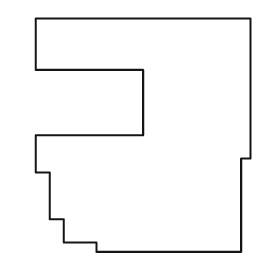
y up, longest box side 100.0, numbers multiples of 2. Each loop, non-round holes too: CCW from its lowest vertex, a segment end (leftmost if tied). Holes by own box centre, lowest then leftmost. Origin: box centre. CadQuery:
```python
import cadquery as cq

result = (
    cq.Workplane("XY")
    .moveTo(-20.0, -50.0)
    .lineTo(42.0, -50.0)
    .lineTo(42.0, -10.0)
    .lineTo(46.0, -10.0)
    .lineTo(46.0, 50.0)
    .lineTo(-46.0, 50.0)
    .lineTo(-46.0, 28.0)
    .lineTo(0.0, 28.0)
    .lineTo(0.0, 0.0)
    .lineTo(-46.0, 0.0)
    .lineTo(-46.0, -16.0)
    .lineTo(-40.0, -16.0)
    .lineTo(-40.0, -36.0)
    .lineTo(-34.0, -36.0)
    .lineTo(-34.0, -46.0)
    .lineTo(-20.0, -46.0)
    .close()
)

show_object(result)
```